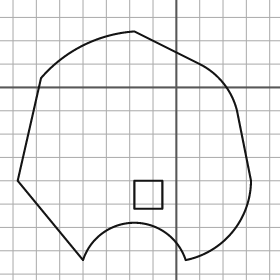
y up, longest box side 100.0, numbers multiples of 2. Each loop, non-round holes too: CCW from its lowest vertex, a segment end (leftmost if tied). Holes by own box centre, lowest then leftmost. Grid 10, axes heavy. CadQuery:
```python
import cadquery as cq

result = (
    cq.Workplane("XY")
    .moveTo(-40.0, -74.0)
    .threePointArc((-18.0, -58.0), (4.0, -74.0))
    .threePointArc((24.0, -62.0), (32.0, -40.0))
    .lineTo(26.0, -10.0)
    .threePointArc((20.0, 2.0), (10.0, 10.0))
    .lineTo(-18.0, 24.0)
    .threePointArc((-40.0, 18.0), (-58.0, 4.0))
    .lineTo(-68.0, -40.0)
    .close()
    .moveTo(-18.0, -52.0)
    .lineTo(-6.0, -52.0)
    .lineTo(-6.0, -40.0)
    .lineTo(-18.0, -40.0)
    .close()
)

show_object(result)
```